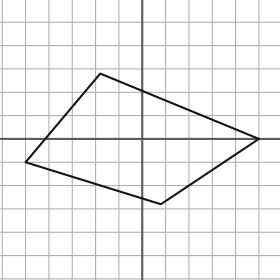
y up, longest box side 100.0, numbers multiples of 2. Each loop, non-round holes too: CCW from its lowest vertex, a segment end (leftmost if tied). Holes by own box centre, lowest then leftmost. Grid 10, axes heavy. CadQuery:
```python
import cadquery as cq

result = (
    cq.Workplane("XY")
    .moveTo(8.0, -28.0)
    .lineTo(50.0, 0.0)
    .lineTo(-18.0, 28.0)
    .lineTo(-50.0, -10.0)
    .close()
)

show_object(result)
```